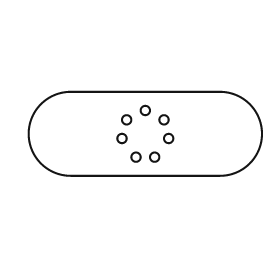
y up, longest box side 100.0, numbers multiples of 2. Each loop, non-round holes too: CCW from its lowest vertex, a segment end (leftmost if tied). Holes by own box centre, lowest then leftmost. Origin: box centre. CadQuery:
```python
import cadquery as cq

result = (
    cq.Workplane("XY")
    .moveTo(-32.0, -18.0)
    .lineTo(32.0, -18.0)
    .threePointArc((50.0, 0.0), (32.0, 18.0))
    .lineTo(-32.0, 18.0)
    .threePointArc((-50.0, 0.0), (-32.0, -18.0))
    .close()
    .moveTo(-4.0, -10.0)
    .circle(2.0)
    .moveTo(4.0, -10.0)
    .circle(2.0)
    .moveTo(-10.0, -2.0)
    .circle(2.0)
    .moveTo(10.0, -2.0)
    .circle(2.0)
    .moveTo(-8.0, 6.0)
    .circle(2.0)
    .moveTo(8.0, 6.0)
    .circle(2.0)
    .moveTo(0.0, 10.0)
    .circle(2.0)
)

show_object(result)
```